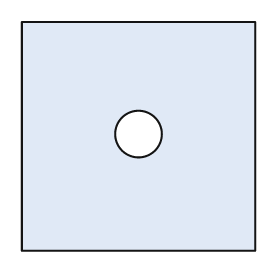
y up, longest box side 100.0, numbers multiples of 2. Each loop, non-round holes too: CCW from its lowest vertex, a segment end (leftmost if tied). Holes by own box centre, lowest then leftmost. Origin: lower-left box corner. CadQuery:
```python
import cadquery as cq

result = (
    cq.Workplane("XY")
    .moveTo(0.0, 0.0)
    .lineTo(100.0, 0.0)
    .lineTo(100.0, 98.0)
    .lineTo(0.0, 98.0)
    .close()
    .moveTo(50.0, 50.0)
    .circle(10.0)
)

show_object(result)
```